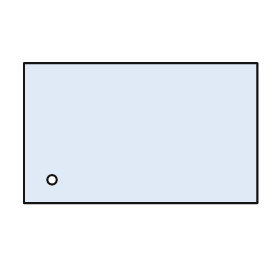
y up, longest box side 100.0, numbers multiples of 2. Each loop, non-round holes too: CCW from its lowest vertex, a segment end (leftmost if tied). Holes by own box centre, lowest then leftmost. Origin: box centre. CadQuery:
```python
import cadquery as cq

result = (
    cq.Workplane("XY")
    .moveTo(-50.0, -30.0)
    .lineTo(50.0, -30.0)
    .lineTo(50.0, 30.0)
    .lineTo(-50.0, 30.0)
    .close()
    .moveTo(-38.0, -20.0)
    .circle(2.0)
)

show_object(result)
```